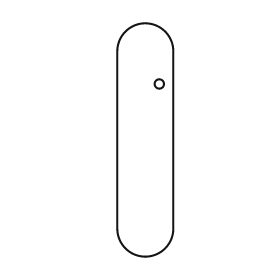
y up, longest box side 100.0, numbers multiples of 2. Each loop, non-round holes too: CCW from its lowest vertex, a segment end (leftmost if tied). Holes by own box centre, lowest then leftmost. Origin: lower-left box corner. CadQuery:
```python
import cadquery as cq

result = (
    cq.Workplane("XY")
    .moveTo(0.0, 12.0)
    .threePointArc((12.0, 0.0), (24.0, 12.0))
    .lineTo(24.0, 88.0)
    .threePointArc((12.0, 100.0), (0.0, 88.0))
    .close()
    .moveTo(18.0, 74.0)
    .circle(2.0)
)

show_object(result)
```